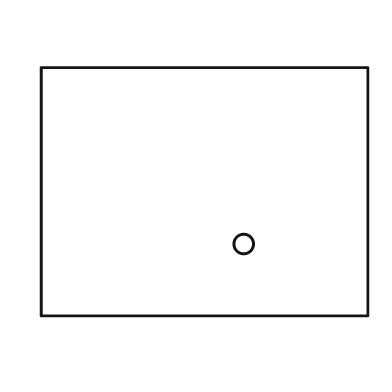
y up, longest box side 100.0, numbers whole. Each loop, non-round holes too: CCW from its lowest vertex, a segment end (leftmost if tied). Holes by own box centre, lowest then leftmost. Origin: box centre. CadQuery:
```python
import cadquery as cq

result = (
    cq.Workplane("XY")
    .moveTo(-50.0, -38.0)
    .lineTo(50.0, -38.0)
    .lineTo(50.0, 38.0)
    .lineTo(-50.0, 38.0)
    .close()
    .moveTo(12.0, -16.0)
    .circle(3.0)
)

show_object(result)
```